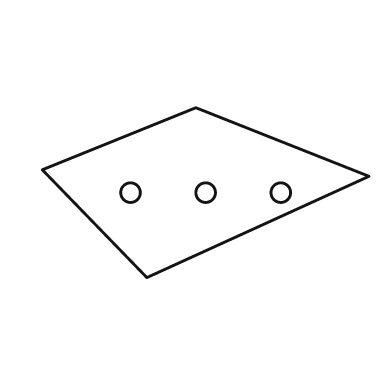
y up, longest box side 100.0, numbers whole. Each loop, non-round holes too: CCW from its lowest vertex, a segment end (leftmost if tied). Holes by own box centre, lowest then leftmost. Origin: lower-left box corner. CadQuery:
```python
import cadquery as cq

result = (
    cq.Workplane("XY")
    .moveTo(32.0, 0.0)
    .lineTo(100.0, 31.0)
    .lineTo(47.0, 52.0)
    .lineTo(0.0, 33.0)
    .close()
    .moveTo(27.0, 26.0)
    .circle(3.0)
    .moveTo(50.0, 26.0)
    .circle(3.0)
    .moveTo(73.0, 26.0)
    .circle(3.0)
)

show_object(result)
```